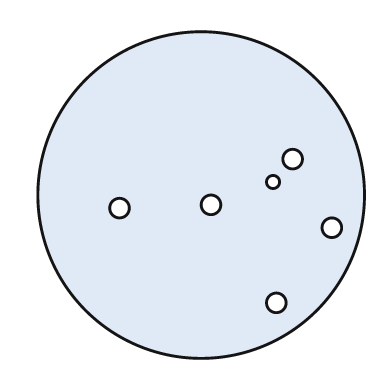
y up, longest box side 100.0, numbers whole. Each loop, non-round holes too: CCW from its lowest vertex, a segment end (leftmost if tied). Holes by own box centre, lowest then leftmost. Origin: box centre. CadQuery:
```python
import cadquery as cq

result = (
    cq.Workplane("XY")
    .moveTo(0.0, 0.0)
    .circle(50.0)
    .moveTo(23.0, -33.0)
    .circle(3.0)
    .moveTo(40.0, -10.0)
    .circle(3.0)
    .moveTo(-25.0, -4.0)
    .circle(3.0)
    .moveTo(3.0, -3.0)
    .circle(3.0)
    .moveTo(22.0, 4.0)
    .circle(2.0)
    .moveTo(28.0, 11.0)
    .circle(3.0)
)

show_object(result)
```